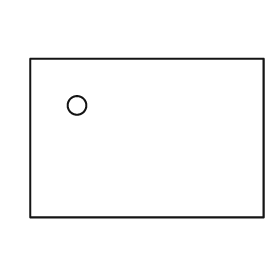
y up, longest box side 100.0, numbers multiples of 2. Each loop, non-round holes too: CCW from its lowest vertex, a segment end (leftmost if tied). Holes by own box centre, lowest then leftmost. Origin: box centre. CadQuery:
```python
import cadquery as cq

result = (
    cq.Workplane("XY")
    .moveTo(-50.0, -34.0)
    .lineTo(50.0, -34.0)
    .lineTo(50.0, 34.0)
    .lineTo(-50.0, 34.0)
    .close()
    .moveTo(-30.0, 14.0)
    .circle(4.0)
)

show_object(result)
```